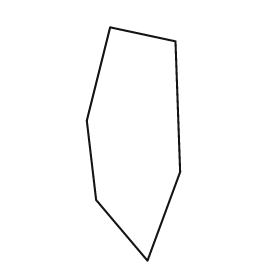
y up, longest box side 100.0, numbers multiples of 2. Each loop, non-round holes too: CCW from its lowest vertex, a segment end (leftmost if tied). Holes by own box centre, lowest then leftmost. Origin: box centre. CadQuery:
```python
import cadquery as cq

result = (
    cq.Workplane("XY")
    .moveTo(6.0, -50.0)
    .lineTo(20.0, -12.0)
    .lineTo(18.0, 44.0)
    .lineTo(-10.0, 50.0)
    .lineTo(-20.0, 10.0)
    .lineTo(-16.0, -24.0)
    .close()
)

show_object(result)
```